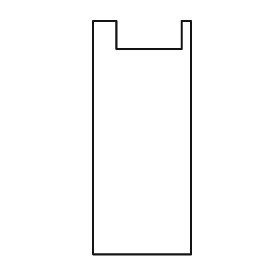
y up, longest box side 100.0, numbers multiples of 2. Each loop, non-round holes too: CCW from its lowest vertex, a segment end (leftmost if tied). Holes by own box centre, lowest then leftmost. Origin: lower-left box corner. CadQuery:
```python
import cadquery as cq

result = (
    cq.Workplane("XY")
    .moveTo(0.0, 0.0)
    .lineTo(42.0, 0.0)
    .lineTo(42.0, 100.0)
    .lineTo(38.0, 100.0)
    .lineTo(38.0, 88.0)
    .lineTo(10.0, 88.0)
    .lineTo(10.0, 100.0)
    .lineTo(0.0, 100.0)
    .close()
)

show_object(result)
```